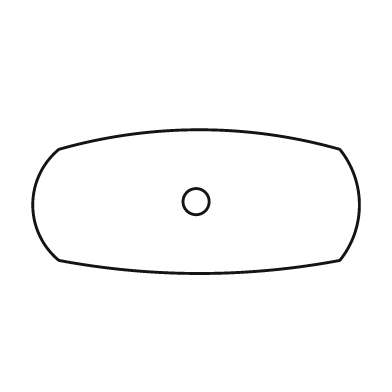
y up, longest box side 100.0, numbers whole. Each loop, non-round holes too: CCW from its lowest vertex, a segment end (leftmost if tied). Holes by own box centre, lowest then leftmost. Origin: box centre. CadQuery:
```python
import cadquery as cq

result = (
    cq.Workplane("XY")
    .moveTo(-42.0, -18.0)
    .threePointArc((1.0, -22.0), (44.0, -18.0))
    .threePointArc((50.0, -1.0), (44.0, 16.0))
    .threePointArc((1.0, 22.0), (-42.0, 16.0))
    .threePointArc((-50.0, -1.0), (-42.0, -18.0))
    .close()
    .moveTo(0.0, 0.0)
    .circle(4.0)
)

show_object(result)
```